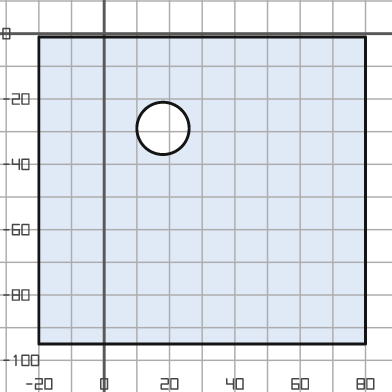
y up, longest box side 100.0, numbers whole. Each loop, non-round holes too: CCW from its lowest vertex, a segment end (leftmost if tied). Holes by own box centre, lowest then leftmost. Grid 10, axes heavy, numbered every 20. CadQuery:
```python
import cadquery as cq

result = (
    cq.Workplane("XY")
    .moveTo(-20.0, -95.0)
    .lineTo(80.0, -95.0)
    .lineTo(80.0, -1.0)
    .lineTo(-20.0, -1.0)
    .close()
    .moveTo(18.0, -29.0)
    .circle(8.0)
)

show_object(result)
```